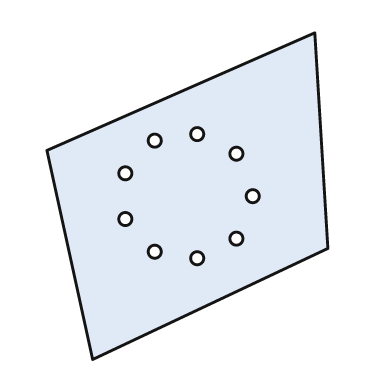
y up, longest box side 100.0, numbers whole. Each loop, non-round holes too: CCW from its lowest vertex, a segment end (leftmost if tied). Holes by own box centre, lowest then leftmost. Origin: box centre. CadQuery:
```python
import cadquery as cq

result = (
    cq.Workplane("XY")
    .moveTo(-29.0, -50.0)
    .lineTo(43.0, -16.0)
    .lineTo(39.0, 50.0)
    .lineTo(-43.0, 14.0)
    .close()
    .moveTo(3.0, -19.0)
    .circle(2.0)
    .moveTo(-10.0, -17.0)
    .circle(2.0)
    .moveTo(15.0, -13.0)
    .circle(2.0)
    .moveTo(-19.0, -7.0)
    .circle(2.0)
    .moveTo(20.0, 0.0)
    .circle(2.0)
    .moveTo(-19.0, 7.0)
    .circle(2.0)
    .moveTo(15.0, 13.0)
    .circle(2.0)
    .moveTo(-10.0, 17.0)
    .circle(2.0)
    .moveTo(3.0, 19.0)
    .circle(2.0)
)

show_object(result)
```